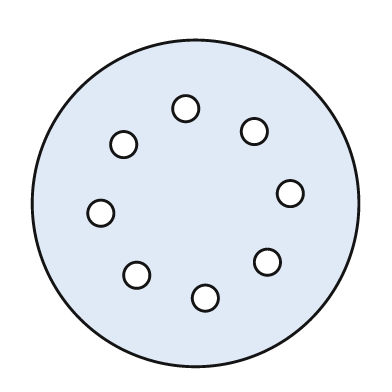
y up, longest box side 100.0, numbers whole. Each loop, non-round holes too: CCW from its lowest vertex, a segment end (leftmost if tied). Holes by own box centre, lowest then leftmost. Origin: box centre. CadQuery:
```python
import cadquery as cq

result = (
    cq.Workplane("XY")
    .moveTo(0.0, 0.0)
    .circle(50.0)
    .moveTo(3.0, -29.0)
    .circle(4.0)
    .moveTo(-18.0, -22.0)
    .circle(4.0)
    .moveTo(22.0, -18.0)
    .circle(4.0)
    .moveTo(-29.0, -3.0)
    .circle(4.0)
    .moveTo(29.0, 3.0)
    .circle(4.0)
    .moveTo(-22.0, 18.0)
    .circle(4.0)
    .moveTo(18.0, 22.0)
    .circle(4.0)
    .moveTo(-3.0, 29.0)
    .circle(4.0)
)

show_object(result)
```